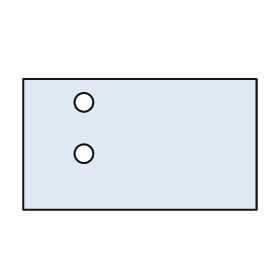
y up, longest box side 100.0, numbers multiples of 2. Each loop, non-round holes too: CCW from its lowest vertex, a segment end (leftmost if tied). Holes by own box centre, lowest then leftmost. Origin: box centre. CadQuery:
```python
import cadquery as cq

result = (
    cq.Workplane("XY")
    .moveTo(-50.0, -28.0)
    .lineTo(50.0, -28.0)
    .lineTo(50.0, 28.0)
    .lineTo(-50.0, 28.0)
    .close()
    .moveTo(-24.0, -4.0)
    .circle(4.0)
    .moveTo(-24.0, 18.0)
    .circle(4.0)
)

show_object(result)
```